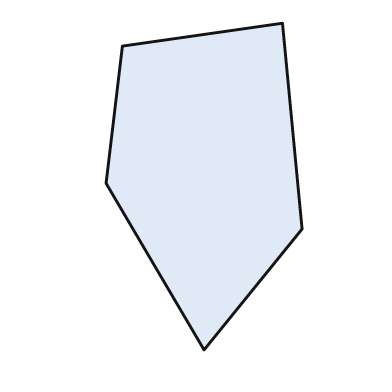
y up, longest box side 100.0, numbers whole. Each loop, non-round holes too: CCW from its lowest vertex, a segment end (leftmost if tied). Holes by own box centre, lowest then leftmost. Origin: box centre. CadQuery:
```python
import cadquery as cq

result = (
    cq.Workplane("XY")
    .moveTo(0.0, -50.0)
    .lineTo(30.0, -13.0)
    .lineTo(24.0, 50.0)
    .lineTo(-25.0, 43.0)
    .lineTo(-30.0, 1.0)
    .close()
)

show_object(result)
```